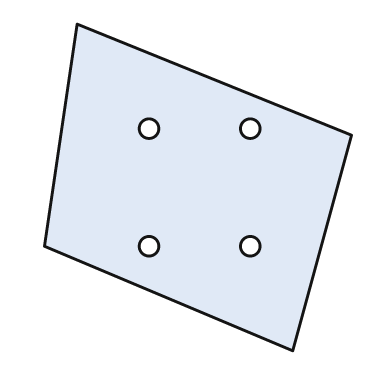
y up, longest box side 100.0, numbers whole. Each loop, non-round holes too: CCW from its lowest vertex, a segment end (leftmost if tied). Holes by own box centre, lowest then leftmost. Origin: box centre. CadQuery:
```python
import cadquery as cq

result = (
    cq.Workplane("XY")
    .moveTo(29.0, -50.0)
    .lineTo(47.0, 16.0)
    .lineTo(-37.0, 50.0)
    .lineTo(-47.0, -18.0)
    .close()
    .moveTo(-15.0, -18.0)
    .circle(3.0)
    .moveTo(16.0, -18.0)
    .circle(3.0)
    .moveTo(-15.0, 18.0)
    .circle(3.0)
    .moveTo(16.0, 18.0)
    .circle(3.0)
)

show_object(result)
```